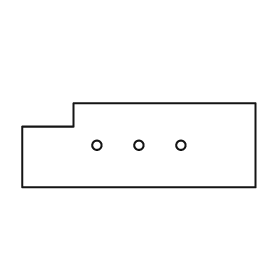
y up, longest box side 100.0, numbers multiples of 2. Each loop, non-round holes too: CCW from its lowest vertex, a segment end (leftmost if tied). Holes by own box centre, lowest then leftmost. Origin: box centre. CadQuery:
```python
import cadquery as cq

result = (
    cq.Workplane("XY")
    .moveTo(-50.0, -18.0)
    .lineTo(50.0, -18.0)
    .lineTo(50.0, 18.0)
    .lineTo(-28.0, 18.0)
    .lineTo(-28.0, 8.0)
    .lineTo(-50.0, 8.0)
    .close()
    .moveTo(-18.0, 0.0)
    .circle(2.0)
    .moveTo(0.0, 0.0)
    .circle(2.0)
    .moveTo(18.0, 0.0)
    .circle(2.0)
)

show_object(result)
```